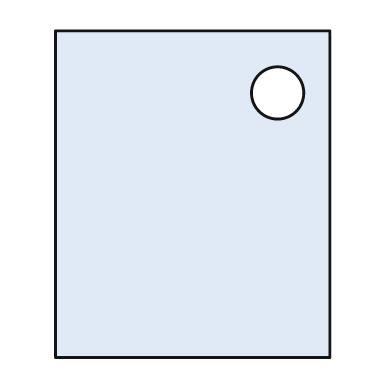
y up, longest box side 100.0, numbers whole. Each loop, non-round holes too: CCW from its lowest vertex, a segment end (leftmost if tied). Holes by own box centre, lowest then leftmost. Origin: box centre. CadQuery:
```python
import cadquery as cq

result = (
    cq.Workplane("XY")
    .moveTo(-42.0, -50.0)
    .lineTo(42.0, -50.0)
    .lineTo(42.0, 50.0)
    .lineTo(-42.0, 50.0)
    .close()
    .moveTo(26.0, 31.0)
    .circle(8.0)
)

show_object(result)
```